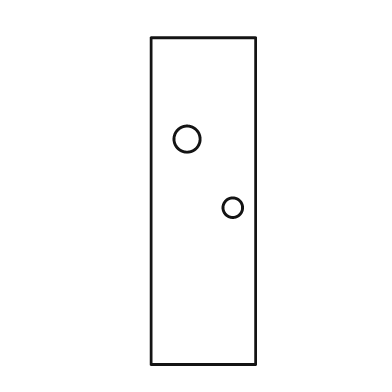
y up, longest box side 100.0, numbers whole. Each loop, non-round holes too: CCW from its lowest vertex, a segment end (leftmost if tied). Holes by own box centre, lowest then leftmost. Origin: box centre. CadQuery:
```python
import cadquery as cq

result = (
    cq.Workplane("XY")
    .moveTo(-16.0, -50.0)
    .lineTo(16.0, -50.0)
    .lineTo(16.0, 50.0)
    .lineTo(-16.0, 50.0)
    .close()
    .moveTo(9.0, -2.0)
    .circle(3.0)
    .moveTo(-5.0, 19.0)
    .circle(4.0)
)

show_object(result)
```